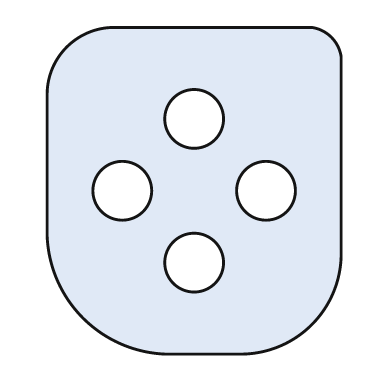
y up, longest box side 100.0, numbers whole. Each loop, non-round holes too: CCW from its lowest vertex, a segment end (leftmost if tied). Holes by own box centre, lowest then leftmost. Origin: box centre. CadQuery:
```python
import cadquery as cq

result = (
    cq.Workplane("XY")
    .moveTo(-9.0, -50.0)
    .lineTo(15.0, -50.0)
    .threePointArc((36.0, -41.0), (45.0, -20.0))
    .lineTo(45.0, 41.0)
    .threePointArc((42.0, 47.0), (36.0, 50.0))
    .lineTo(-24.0, 50.0)
    .threePointArc((-39.0, 44.0), (-45.0, 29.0))
    .lineTo(-45.0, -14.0)
    .threePointArc((-34.0, -39.0), (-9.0, -50.0))
    .close()
    .moveTo(0.0, -22.0)
    .circle(9.0)
    .moveTo(-22.0, 0.0)
    .circle(9.0)
    .moveTo(22.0, 0.0)
    .circle(9.0)
    .moveTo(0.0, 22.0)
    .circle(9.0)
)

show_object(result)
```